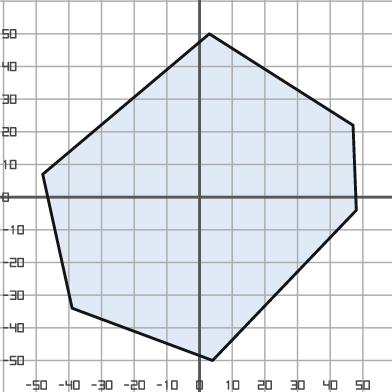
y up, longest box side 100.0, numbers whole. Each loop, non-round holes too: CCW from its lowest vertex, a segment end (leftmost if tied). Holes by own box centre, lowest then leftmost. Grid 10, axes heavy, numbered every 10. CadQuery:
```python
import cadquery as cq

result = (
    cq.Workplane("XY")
    .moveTo(4.0, -50.0)
    .lineTo(48.0, -4.0)
    .lineTo(47.0, 22.0)
    .lineTo(3.0, 50.0)
    .lineTo(-48.0, 7.0)
    .lineTo(-39.0, -34.0)
    .close()
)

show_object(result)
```